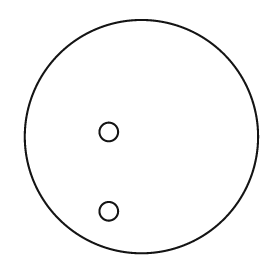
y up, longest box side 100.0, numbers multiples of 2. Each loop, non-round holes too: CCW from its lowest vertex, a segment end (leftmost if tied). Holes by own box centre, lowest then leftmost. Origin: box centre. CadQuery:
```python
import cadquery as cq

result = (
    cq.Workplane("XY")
    .moveTo(0.0, 0.0)
    .circle(50.0)
    .moveTo(-14.0, -32.0)
    .circle(4.0)
    .moveTo(-14.0, 2.0)
    .circle(4.0)
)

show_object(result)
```